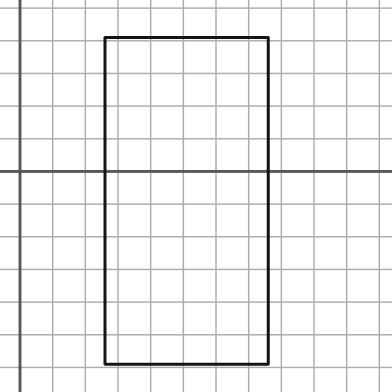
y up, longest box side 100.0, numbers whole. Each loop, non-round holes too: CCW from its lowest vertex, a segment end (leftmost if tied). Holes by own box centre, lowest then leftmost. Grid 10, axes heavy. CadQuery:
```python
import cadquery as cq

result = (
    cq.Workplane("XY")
    .moveTo(26.0, -59.0)
    .lineTo(76.0, -59.0)
    .lineTo(76.0, 41.0)
    .lineTo(26.0, 41.0)
    .close()
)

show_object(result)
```